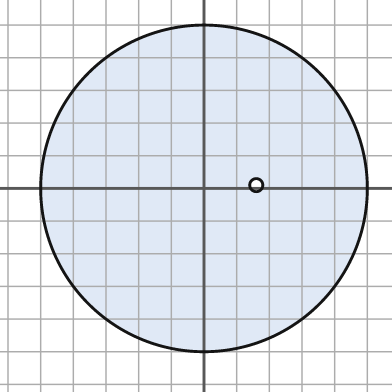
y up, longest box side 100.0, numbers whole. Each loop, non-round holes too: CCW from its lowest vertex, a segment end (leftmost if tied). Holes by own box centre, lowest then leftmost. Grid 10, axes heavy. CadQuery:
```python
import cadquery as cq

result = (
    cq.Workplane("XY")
    .moveTo(0.0, 0.0)
    .circle(50.0)
    .moveTo(16.0, 1.0)
    .circle(2.0)
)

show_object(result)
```